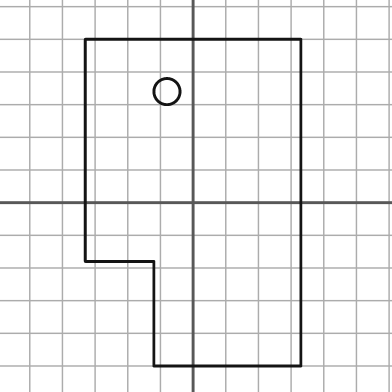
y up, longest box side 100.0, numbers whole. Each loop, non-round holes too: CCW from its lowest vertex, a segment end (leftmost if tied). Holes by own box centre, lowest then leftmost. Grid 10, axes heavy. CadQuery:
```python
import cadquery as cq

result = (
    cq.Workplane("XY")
    .moveTo(-12.0, -50.0)
    .lineTo(33.0, -50.0)
    .lineTo(33.0, 50.0)
    .lineTo(-33.0, 50.0)
    .lineTo(-33.0, -18.0)
    .lineTo(-12.0, -18.0)
    .close()
    .moveTo(-8.0, 34.0)
    .circle(4.0)
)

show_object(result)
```